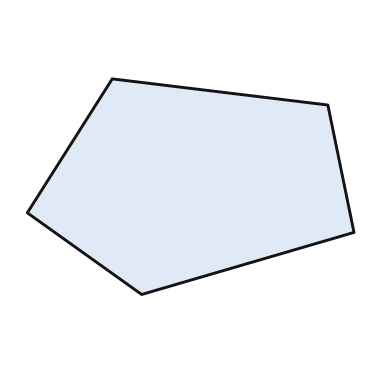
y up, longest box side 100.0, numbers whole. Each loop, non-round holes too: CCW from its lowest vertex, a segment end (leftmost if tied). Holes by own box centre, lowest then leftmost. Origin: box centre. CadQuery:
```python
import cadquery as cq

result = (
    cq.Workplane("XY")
    .moveTo(-15.0, -33.0)
    .lineTo(50.0, -14.0)
    .lineTo(42.0, 25.0)
    .lineTo(-24.0, 33.0)
    .lineTo(-50.0, -8.0)
    .close()
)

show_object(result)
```